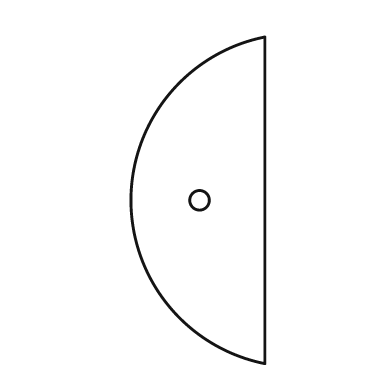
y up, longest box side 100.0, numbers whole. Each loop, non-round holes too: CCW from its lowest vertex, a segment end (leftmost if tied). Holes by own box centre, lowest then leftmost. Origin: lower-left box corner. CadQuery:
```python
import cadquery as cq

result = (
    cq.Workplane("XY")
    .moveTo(41.0, 0.0)
    .lineTo(41.0, 100.0)
    .threePointArc((0.0, 50.0), (41.0, 0.0))
    .close()
    .moveTo(21.0, 50.0)
    .circle(3.0)
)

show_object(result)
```